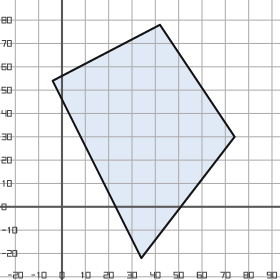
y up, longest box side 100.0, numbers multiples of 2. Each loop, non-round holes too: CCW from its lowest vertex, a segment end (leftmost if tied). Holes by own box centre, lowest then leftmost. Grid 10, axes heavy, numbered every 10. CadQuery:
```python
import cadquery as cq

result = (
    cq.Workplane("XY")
    .moveTo(34.0, -22.0)
    .lineTo(74.0, 30.0)
    .lineTo(42.0, 78.0)
    .lineTo(-4.0, 54.0)
    .close()
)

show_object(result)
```